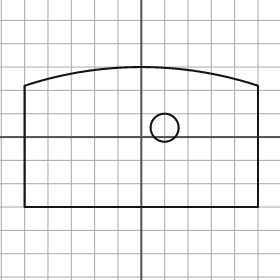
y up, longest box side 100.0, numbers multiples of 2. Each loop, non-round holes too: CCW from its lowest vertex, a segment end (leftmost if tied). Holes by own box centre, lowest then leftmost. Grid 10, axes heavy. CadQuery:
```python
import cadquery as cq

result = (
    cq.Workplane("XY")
    .moveTo(-50.0, -30.0)
    .lineTo(50.0, -30.0)
    .lineTo(50.0, 22.0)
    .threePointArc((0.0, 30.0), (-50.0, 22.0))
    .close()
    .moveTo(10.0, 4.0)
    .circle(6.0)
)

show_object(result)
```